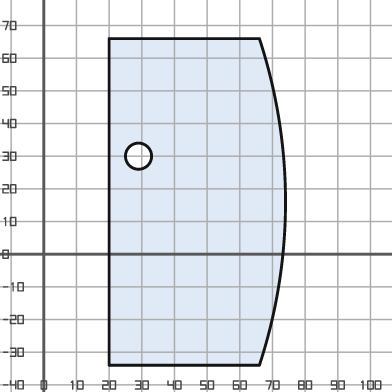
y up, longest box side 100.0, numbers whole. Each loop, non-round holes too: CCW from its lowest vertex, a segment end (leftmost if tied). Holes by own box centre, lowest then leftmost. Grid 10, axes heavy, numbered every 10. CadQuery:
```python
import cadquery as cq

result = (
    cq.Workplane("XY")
    .moveTo(20.0, -34.0)
    .lineTo(66.0, -34.0)
    .threePointArc((74.0, 16.0), (66.0, 66.0))
    .lineTo(20.0, 66.0)
    .close()
    .moveTo(29.0, 30.0)
    .circle(4.0)
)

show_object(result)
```